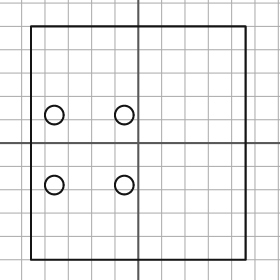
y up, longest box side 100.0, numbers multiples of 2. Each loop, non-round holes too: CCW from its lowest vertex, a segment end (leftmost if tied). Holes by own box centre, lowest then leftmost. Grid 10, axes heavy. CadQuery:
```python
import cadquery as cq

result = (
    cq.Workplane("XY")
    .moveTo(-46.0, -50.0)
    .lineTo(46.0, -50.0)
    .lineTo(46.0, 50.0)
    .lineTo(-46.0, 50.0)
    .close()
    .moveTo(-36.0, -18.0)
    .circle(4.0)
    .moveTo(-6.0, -18.0)
    .circle(4.0)
    .moveTo(-36.0, 12.0)
    .circle(4.0)
    .moveTo(-6.0, 12.0)
    .circle(4.0)
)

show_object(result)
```